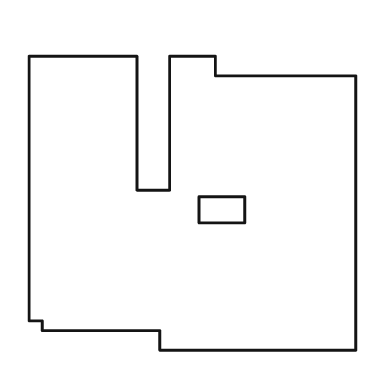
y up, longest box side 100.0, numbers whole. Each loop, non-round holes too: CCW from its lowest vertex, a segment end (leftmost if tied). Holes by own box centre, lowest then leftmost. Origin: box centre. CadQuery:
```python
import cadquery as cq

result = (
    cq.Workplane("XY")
    .moveTo(-10.0, -45.0)
    .lineTo(50.0, -45.0)
    .lineTo(50.0, 39.0)
    .lineTo(7.0, 39.0)
    .lineTo(7.0, 45.0)
    .lineTo(-7.0, 45.0)
    .lineTo(-7.0, 4.0)
    .lineTo(-17.0, 4.0)
    .lineTo(-17.0, 45.0)
    .lineTo(-50.0, 45.0)
    .lineTo(-50.0, -36.0)
    .lineTo(-46.0, -36.0)
    .lineTo(-46.0, -39.0)
    .lineTo(-10.0, -39.0)
    .close()
    .moveTo(2.0, -6.0)
    .lineTo(16.0, -6.0)
    .lineTo(16.0, 2.0)
    .lineTo(2.0, 2.0)
    .close()
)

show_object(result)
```